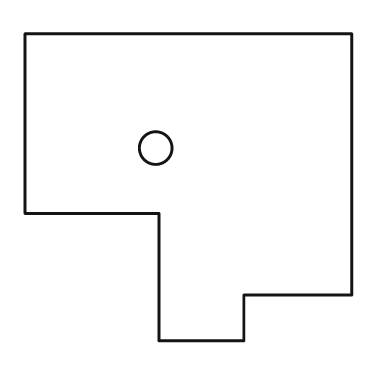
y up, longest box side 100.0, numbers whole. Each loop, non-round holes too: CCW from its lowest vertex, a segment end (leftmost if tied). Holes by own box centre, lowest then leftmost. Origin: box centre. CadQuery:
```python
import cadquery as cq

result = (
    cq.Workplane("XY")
    .moveTo(-9.0, -47.0)
    .lineTo(17.0, -47.0)
    .lineTo(17.0, -33.0)
    .lineTo(50.0, -33.0)
    .lineTo(50.0, 47.0)
    .lineTo(-50.0, 47.0)
    .lineTo(-50.0, -8.0)
    .lineTo(-9.0, -8.0)
    .close()
    .moveTo(-10.0, 12.0)
    .circle(5.0)
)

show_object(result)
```